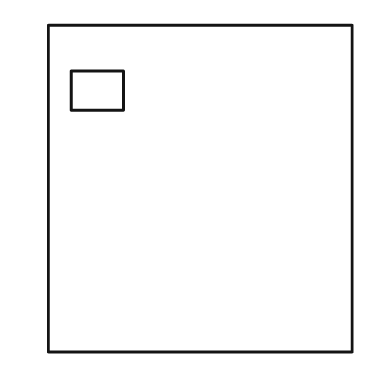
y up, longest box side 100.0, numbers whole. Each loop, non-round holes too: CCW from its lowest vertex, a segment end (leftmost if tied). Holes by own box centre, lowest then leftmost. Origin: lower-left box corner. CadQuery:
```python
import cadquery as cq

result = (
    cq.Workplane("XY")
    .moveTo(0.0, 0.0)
    .lineTo(93.0, 0.0)
    .lineTo(93.0, 100.0)
    .lineTo(0.0, 100.0)
    .close()
    .moveTo(7.0, 74.0)
    .lineTo(23.0, 74.0)
    .lineTo(23.0, 86.0)
    .lineTo(7.0, 86.0)
    .close()
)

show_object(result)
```